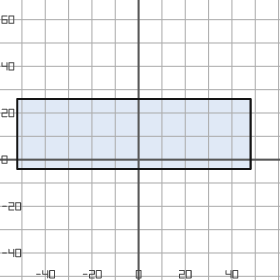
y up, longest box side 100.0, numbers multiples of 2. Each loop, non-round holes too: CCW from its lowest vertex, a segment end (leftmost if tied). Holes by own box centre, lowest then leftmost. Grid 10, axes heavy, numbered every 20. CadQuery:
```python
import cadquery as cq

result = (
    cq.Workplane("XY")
    .moveTo(-52.0, -4.0)
    .lineTo(48.0, -4.0)
    .lineTo(48.0, 26.0)
    .lineTo(-52.0, 26.0)
    .close()
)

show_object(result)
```